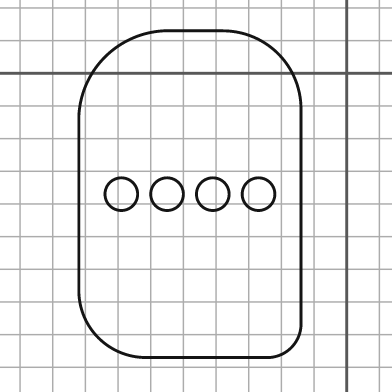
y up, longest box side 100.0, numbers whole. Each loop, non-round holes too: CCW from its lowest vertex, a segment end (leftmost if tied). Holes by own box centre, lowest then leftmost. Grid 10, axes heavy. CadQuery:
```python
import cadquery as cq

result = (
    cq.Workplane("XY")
    .moveTo(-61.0, -87.0)
    .lineTo(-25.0, -87.0)
    .threePointArc((-17.0, -84.0), (-14.0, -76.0))
    .lineTo(-14.0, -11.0)
    .threePointArc((-21.0, 6.0), (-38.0, 13.0))
    .lineTo(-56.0, 13.0)
    .threePointArc((-74.0, 5.0), (-82.0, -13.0))
    .lineTo(-82.0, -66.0)
    .threePointArc((-76.0, -81.0), (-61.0, -87.0))
    .close()
    .moveTo(-69.0, -37.0)
    .circle(5.0)
    .moveTo(-55.0, -37.0)
    .circle(5.0)
    .moveTo(-41.0, -37.0)
    .circle(5.0)
    .moveTo(-27.0, -37.0)
    .circle(5.0)
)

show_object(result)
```